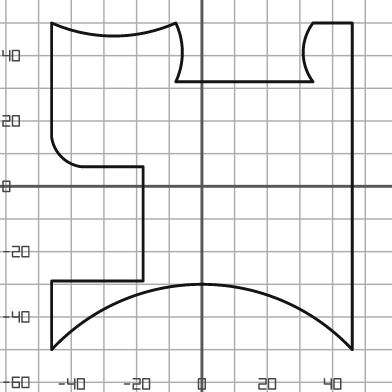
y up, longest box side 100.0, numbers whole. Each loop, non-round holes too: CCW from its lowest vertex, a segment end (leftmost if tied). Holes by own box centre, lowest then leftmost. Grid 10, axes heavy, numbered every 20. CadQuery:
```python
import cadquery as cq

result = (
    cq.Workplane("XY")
    .moveTo(-46.0, -50.0)
    .threePointArc((0.0, -30.0), (46.0, -50.0))
    .lineTo(46.0, 50.0)
    .lineTo(34.0, 50.0)
    .threePointArc((31.0, 41.0), (34.0, 32.0))
    .lineTo(-8.0, 32.0)
    .threePointArc((-6.0, 41.0), (-8.0, 50.0))
    .threePointArc((-27.0, 46.0), (-46.0, 50.0))
    .lineTo(-46.0, 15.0)
    .threePointArc((-43.0, 9.0), (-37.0, 6.0))
    .lineTo(-18.0, 6.0)
    .lineTo(-18.0, -29.0)
    .lineTo(-46.0, -29.0)
    .close()
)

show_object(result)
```